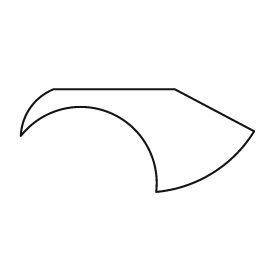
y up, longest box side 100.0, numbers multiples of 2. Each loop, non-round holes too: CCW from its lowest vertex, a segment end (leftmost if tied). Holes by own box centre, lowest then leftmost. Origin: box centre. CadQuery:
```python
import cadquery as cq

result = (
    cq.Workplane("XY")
    .moveTo(8.0, -22.0)
    .threePointArc((32.0, -14.0), (50.0, 4.0))
    .lineTo(16.0, 22.0)
    .lineTo(-36.0, 22.0)
    .threePointArc((-46.0, 14.0), (-50.0, 2.0))
    .threePointArc((-12.0, 12.0), (8.0, -22.0))
    .close()
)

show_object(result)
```